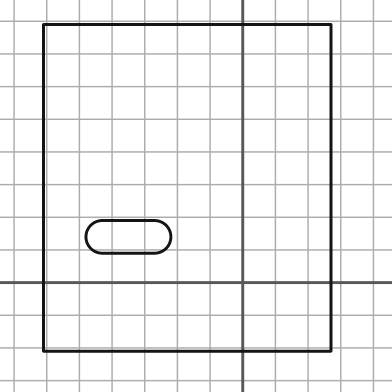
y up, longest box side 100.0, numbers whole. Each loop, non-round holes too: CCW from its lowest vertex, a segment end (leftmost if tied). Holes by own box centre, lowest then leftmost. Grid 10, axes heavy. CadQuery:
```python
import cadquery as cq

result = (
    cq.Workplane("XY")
    .moveTo(-61.0, -21.0)
    .lineTo(27.0, -21.0)
    .lineTo(27.0, 79.0)
    .lineTo(-61.0, 79.0)
    .close()
    .moveTo(-43.0, 9.0)
    .lineTo(-27.0, 9.0)
    .threePointArc((-22.0, 14.0), (-27.0, 19.0))
    .lineTo(-43.0, 19.0)
    .threePointArc((-48.0, 14.0), (-43.0, 9.0))
    .close()
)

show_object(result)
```